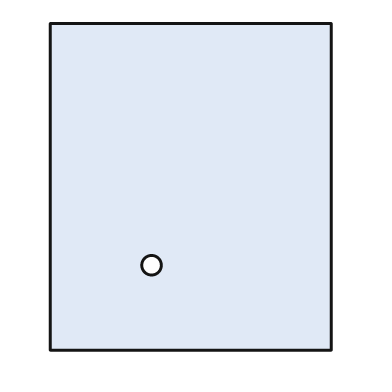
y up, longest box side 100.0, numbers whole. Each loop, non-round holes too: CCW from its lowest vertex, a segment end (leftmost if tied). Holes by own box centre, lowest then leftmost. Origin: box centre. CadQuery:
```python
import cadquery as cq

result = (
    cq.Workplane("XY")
    .moveTo(-43.0, -50.0)
    .lineTo(43.0, -50.0)
    .lineTo(43.0, 50.0)
    .lineTo(-43.0, 50.0)
    .close()
    .moveTo(-12.0, -24.0)
    .circle(3.0)
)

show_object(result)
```